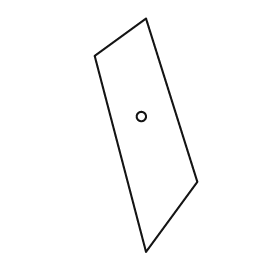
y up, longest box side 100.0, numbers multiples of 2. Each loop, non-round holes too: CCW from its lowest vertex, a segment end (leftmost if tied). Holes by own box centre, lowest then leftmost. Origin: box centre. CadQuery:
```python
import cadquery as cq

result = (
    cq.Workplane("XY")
    .moveTo(0.0, -50.0)
    .lineTo(22.0, -20.0)
    .lineTo(0.0, 50.0)
    .lineTo(-22.0, 34.0)
    .close()
    .moveTo(-2.0, 8.0)
    .circle(2.0)
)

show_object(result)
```